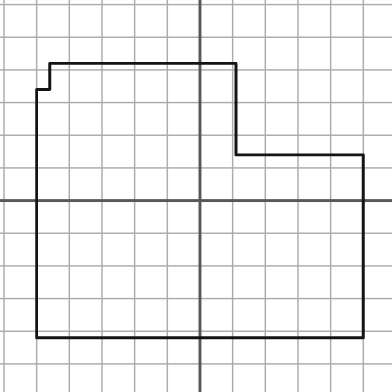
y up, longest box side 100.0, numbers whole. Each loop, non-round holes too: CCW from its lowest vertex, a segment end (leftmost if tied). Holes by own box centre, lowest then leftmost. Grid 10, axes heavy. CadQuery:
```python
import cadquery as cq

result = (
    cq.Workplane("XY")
    .moveTo(-50.0, -42.0)
    .lineTo(50.0, -42.0)
    .lineTo(50.0, 14.0)
    .lineTo(11.0, 14.0)
    .lineTo(11.0, 42.0)
    .lineTo(-46.0, 42.0)
    .lineTo(-46.0, 34.0)
    .lineTo(-50.0, 34.0)
    .close()
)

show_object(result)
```